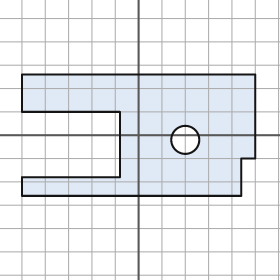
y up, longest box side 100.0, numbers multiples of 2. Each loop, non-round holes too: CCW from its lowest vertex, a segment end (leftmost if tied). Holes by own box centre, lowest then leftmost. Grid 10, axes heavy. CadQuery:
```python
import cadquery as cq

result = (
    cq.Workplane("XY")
    .moveTo(-50.0, -26.0)
    .lineTo(44.0, -26.0)
    .lineTo(44.0, -10.0)
    .lineTo(50.0, -10.0)
    .lineTo(50.0, 26.0)
    .lineTo(-50.0, 26.0)
    .lineTo(-50.0, 10.0)
    .lineTo(-8.0, 10.0)
    .lineTo(-8.0, -18.0)
    .lineTo(-50.0, -18.0)
    .close()
    .moveTo(20.0, -2.0)
    .circle(6.0)
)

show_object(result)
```